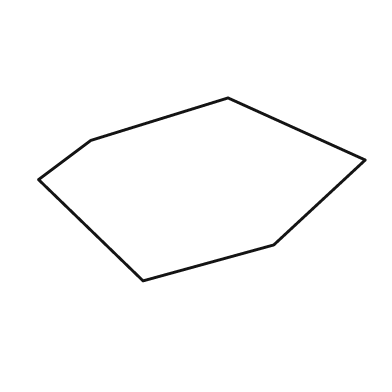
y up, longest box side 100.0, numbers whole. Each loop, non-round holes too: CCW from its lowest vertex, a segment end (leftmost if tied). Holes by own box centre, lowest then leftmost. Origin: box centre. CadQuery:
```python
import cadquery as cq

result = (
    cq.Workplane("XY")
    .moveTo(-18.0, -28.0)
    .lineTo(22.0, -17.0)
    .lineTo(50.0, 9.0)
    .lineTo(8.0, 28.0)
    .lineTo(-34.0, 15.0)
    .lineTo(-50.0, 3.0)
    .close()
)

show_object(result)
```